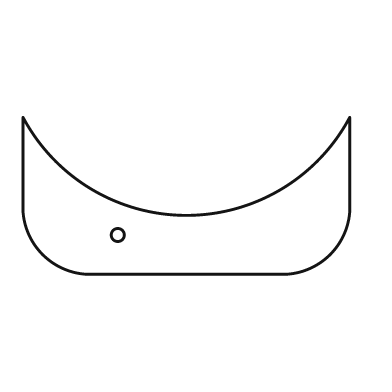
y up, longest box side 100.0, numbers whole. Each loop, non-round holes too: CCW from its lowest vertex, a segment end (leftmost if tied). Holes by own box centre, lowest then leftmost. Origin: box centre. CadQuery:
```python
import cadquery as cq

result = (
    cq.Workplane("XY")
    .moveTo(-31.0, -24.0)
    .lineTo(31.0, -24.0)
    .threePointArc((44.0, -18.0), (50.0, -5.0))
    .lineTo(50.0, 24.0)
    .threePointArc((0.0, -6.0), (-50.0, 24.0))
    .lineTo(-50.0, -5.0)
    .threePointArc((-44.0, -18.0), (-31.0, -24.0))
    .close()
    .moveTo(-21.0, -12.0)
    .circle(2.0)
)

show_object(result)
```